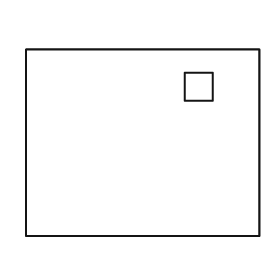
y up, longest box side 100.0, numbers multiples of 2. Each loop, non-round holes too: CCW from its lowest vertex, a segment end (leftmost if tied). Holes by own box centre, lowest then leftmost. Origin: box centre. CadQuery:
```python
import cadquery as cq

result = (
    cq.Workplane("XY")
    .moveTo(-50.0, -40.0)
    .lineTo(50.0, -40.0)
    .lineTo(50.0, 40.0)
    .lineTo(-50.0, 40.0)
    .close()
    .moveTo(18.0, 18.0)
    .lineTo(30.0, 18.0)
    .lineTo(30.0, 30.0)
    .lineTo(18.0, 30.0)
    .close()
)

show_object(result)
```